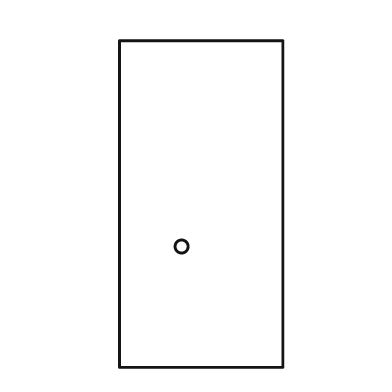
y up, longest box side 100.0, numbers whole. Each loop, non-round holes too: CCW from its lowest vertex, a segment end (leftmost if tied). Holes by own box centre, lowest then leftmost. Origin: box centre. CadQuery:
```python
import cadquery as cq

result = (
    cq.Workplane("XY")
    .moveTo(-25.0, -50.0)
    .lineTo(25.0, -50.0)
    .lineTo(25.0, 50.0)
    .lineTo(-25.0, 50.0)
    .close()
    .moveTo(-6.0, -13.0)
    .circle(2.0)
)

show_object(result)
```